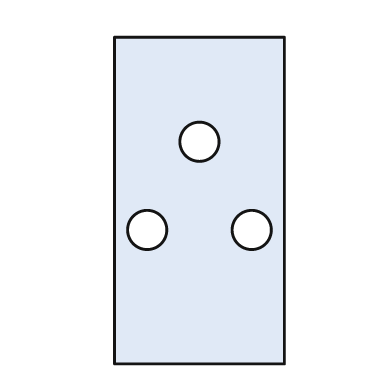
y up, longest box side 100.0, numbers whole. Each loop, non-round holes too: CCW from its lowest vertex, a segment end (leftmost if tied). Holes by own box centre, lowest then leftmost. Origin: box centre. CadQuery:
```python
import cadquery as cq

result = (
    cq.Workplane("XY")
    .moveTo(-26.0, -50.0)
    .lineTo(26.0, -50.0)
    .lineTo(26.0, 50.0)
    .lineTo(-26.0, 50.0)
    .close()
    .moveTo(-16.0, -9.0)
    .circle(6.0)
    .moveTo(16.0, -9.0)
    .circle(6.0)
    .moveTo(0.0, 18.0)
    .circle(6.0)
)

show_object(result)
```